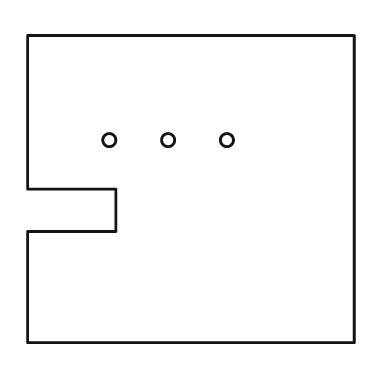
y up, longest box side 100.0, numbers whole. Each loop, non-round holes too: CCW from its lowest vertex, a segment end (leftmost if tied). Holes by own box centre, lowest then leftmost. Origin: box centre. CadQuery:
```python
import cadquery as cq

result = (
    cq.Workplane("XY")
    .moveTo(-50.0, -47.0)
    .lineTo(50.0, -47.0)
    .lineTo(50.0, 47.0)
    .lineTo(-50.0, 47.0)
    .lineTo(-50.0, 0.0)
    .lineTo(-23.0, 0.0)
    .lineTo(-23.0, -13.0)
    .lineTo(-50.0, -13.0)
    .close()
    .moveTo(-25.0, 15.0)
    .circle(2.0)
    .moveTo(-7.0, 15.0)
    .circle(2.0)
    .moveTo(11.0, 15.0)
    .circle(2.0)
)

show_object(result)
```